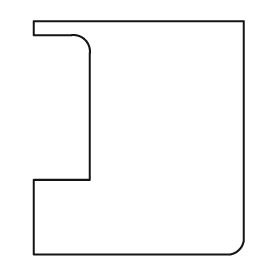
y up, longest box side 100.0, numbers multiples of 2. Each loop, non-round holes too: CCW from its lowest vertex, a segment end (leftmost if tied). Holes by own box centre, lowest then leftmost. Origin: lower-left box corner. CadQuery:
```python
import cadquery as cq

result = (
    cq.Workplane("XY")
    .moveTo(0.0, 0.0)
    .lineTo(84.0, 0.0)
    .threePointArc((88.0, 2.0), (90.0, 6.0))
    .lineTo(90.0, 100.0)
    .lineTo(0.0, 100.0)
    .lineTo(0.0, 94.0)
    .lineTo(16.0, 94.0)
    .threePointArc((22.0, 92.0), (24.0, 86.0))
    .lineTo(24.0, 32.0)
    .lineTo(0.0, 32.0)
    .close()
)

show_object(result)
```